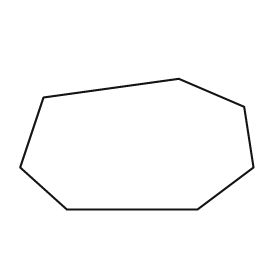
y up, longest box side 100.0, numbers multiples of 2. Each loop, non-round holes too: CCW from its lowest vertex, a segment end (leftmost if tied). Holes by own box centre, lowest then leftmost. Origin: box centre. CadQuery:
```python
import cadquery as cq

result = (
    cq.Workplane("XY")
    .moveTo(-30.0, -28.0)
    .lineTo(26.0, -28.0)
    .lineTo(50.0, -10.0)
    .lineTo(46.0, 16.0)
    .lineTo(18.0, 28.0)
    .lineTo(-40.0, 20.0)
    .lineTo(-50.0, -10.0)
    .close()
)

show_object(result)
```